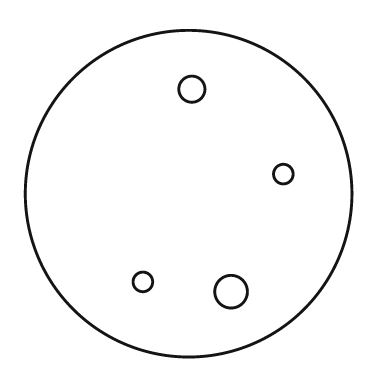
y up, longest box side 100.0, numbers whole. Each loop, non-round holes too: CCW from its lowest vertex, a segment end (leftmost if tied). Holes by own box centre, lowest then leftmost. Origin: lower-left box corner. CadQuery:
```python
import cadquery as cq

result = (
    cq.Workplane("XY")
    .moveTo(50.0, 50.0)
    .circle(50.0)
    .moveTo(63.0, 20.0)
    .circle(5.0)
    .moveTo(36.0, 23.0)
    .circle(3.0)
    .moveTo(79.0, 56.0)
    .circle(3.0)
    .moveTo(51.0, 82.0)
    .circle(4.0)
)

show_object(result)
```